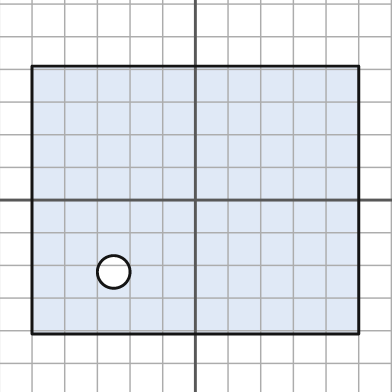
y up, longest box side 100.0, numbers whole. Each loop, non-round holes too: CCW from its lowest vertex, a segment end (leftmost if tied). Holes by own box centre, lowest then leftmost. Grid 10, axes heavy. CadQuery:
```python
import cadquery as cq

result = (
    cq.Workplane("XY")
    .moveTo(-50.0, -41.0)
    .lineTo(50.0, -41.0)
    .lineTo(50.0, 41.0)
    .lineTo(-50.0, 41.0)
    .close()
    .moveTo(-25.0, -22.0)
    .circle(5.0)
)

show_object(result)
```